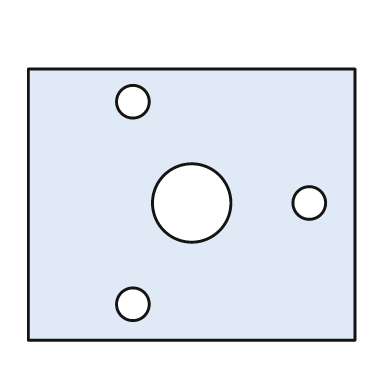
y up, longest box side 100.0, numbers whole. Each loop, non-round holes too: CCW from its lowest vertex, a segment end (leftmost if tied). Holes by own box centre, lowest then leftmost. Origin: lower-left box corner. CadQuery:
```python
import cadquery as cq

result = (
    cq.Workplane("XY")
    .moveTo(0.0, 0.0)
    .lineTo(100.0, 0.0)
    .lineTo(100.0, 83.0)
    .lineTo(0.0, 83.0)
    .close()
    .moveTo(32.0, 11.0)
    .circle(5.0)
    .moveTo(50.0, 42.0)
    .circle(12.0)
    .moveTo(86.0, 42.0)
    .circle(5.0)
    .moveTo(32.0, 73.0)
    .circle(5.0)
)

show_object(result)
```